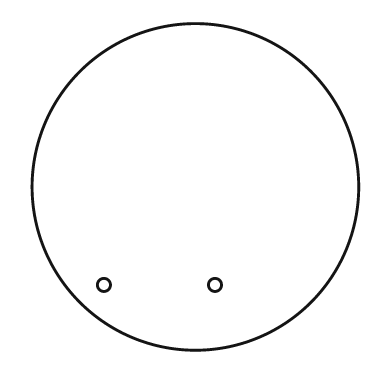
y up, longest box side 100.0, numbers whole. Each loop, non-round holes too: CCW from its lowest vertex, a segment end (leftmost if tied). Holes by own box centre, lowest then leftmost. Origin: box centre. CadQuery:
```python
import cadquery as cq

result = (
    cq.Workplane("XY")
    .moveTo(0.0, 0.0)
    .circle(50.0)
    .moveTo(-28.0, -30.0)
    .circle(2.0)
    .moveTo(6.0, -30.0)
    .circle(2.0)
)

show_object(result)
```